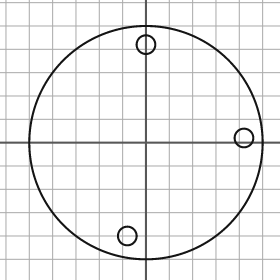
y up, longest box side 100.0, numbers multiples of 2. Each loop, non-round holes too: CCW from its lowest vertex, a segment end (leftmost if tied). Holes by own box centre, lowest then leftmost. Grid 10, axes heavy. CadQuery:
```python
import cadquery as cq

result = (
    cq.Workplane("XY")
    .moveTo(0.0, 0.0)
    .circle(50.0)
    .moveTo(-8.0, -40.0)
    .circle(4.0)
    .moveTo(42.0, 2.0)
    .circle(4.0)
    .moveTo(0.0, 42.0)
    .circle(4.0)
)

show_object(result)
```